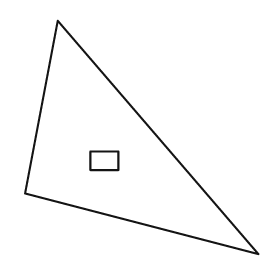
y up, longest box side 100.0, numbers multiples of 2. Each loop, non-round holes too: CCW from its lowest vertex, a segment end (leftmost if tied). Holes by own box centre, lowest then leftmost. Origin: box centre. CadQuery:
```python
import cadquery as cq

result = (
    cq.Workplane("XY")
    .moveTo(50.0, -50.0)
    .lineTo(-36.0, 50.0)
    .lineTo(-50.0, -24.0)
    .close()
    .moveTo(-22.0, -14.0)
    .lineTo(-10.0, -14.0)
    .lineTo(-10.0, -6.0)
    .lineTo(-22.0, -6.0)
    .close()
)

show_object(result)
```